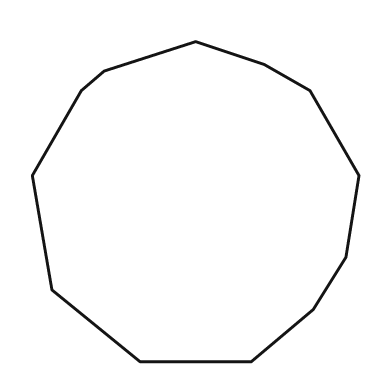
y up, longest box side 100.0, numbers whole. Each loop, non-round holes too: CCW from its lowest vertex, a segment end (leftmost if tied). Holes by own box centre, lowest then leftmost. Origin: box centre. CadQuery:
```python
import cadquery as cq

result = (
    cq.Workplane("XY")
    .moveTo(-17.0, -49.0)
    .lineTo(17.0, -49.0)
    .lineTo(36.0, -33.0)
    .lineTo(46.0, -17.0)
    .lineTo(50.0, 8.0)
    .lineTo(35.0, 34.0)
    .lineTo(21.0, 42.0)
    .lineTo(0.0, 49.0)
    .lineTo(-28.0, 40.0)
    .lineTo(-35.0, 34.0)
    .lineTo(-50.0, 8.0)
    .lineTo(-44.0, -27.0)
    .close()
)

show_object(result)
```